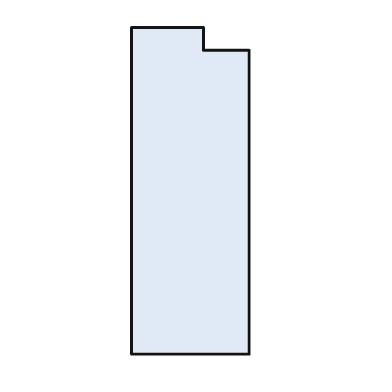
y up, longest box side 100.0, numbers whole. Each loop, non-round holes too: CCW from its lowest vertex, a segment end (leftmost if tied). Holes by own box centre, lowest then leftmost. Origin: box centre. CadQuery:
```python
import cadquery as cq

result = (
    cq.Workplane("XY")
    .moveTo(-18.0, -50.0)
    .lineTo(18.0, -50.0)
    .lineTo(18.0, 43.0)
    .lineTo(4.0, 43.0)
    .lineTo(4.0, 50.0)
    .lineTo(-18.0, 50.0)
    .close()
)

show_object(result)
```